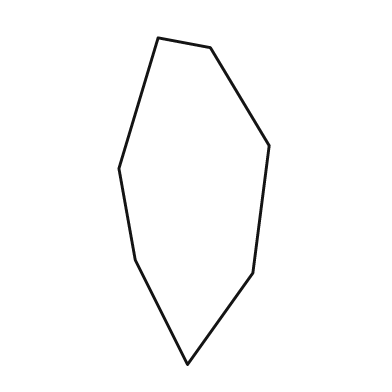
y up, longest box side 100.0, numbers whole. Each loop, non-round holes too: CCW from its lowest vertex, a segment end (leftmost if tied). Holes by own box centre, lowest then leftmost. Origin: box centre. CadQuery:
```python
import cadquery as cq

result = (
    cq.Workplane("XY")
    .moveTo(-2.0, -50.0)
    .lineTo(18.0, -22.0)
    .lineTo(23.0, 17.0)
    .lineTo(5.0, 47.0)
    .lineTo(-11.0, 50.0)
    .lineTo(-23.0, 10.0)
    .lineTo(-18.0, -18.0)
    .close()
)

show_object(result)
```